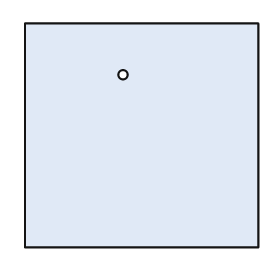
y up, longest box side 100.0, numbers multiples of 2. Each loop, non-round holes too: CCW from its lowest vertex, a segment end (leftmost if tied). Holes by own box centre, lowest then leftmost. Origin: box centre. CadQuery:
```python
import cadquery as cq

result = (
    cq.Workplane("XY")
    .moveTo(-50.0, -48.0)
    .lineTo(50.0, -48.0)
    .lineTo(50.0, 48.0)
    .lineTo(-50.0, 48.0)
    .close()
    .moveTo(-8.0, 26.0)
    .circle(2.0)
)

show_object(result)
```